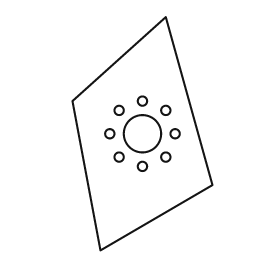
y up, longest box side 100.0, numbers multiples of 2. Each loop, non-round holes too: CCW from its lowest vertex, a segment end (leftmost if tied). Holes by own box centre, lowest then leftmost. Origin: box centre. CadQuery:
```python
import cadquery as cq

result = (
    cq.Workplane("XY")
    .moveTo(-18.0, -50.0)
    .lineTo(30.0, -22.0)
    .lineTo(10.0, 50.0)
    .lineTo(-30.0, 14.0)
    .close()
    .moveTo(0.0, -14.0)
    .circle(2.0)
    .moveTo(-10.0, -10.0)
    .circle(2.0)
    .moveTo(10.0, -10.0)
    .circle(2.0)
    .moveTo(-14.0, 0.0)
    .circle(2.0)
    .moveTo(0.0, 0.0)
    .circle(8.0)
    .moveTo(14.0, 0.0)
    .circle(2.0)
    .moveTo(-10.0, 10.0)
    .circle(2.0)
    .moveTo(10.0, 10.0)
    .circle(2.0)
    .moveTo(0.0, 14.0)
    .circle(2.0)
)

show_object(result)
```